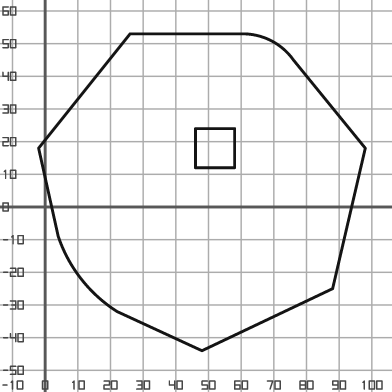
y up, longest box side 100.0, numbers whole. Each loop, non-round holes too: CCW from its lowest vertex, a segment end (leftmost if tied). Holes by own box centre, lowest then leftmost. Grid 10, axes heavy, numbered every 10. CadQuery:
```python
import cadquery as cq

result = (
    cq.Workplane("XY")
    .moveTo(48.0, -44.0)
    .lineTo(88.0, -25.0)
    .lineTo(98.0, 18.0)
    .lineTo(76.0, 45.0)
    .threePointArc((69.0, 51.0), (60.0, 53.0))
    .lineTo(26.0, 53.0)
    .lineTo(-2.0, 18.0)
    .lineTo(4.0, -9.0)
    .threePointArc((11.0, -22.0), (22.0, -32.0))
    .close()
    .moveTo(46.0, 12.0)
    .lineTo(58.0, 12.0)
    .lineTo(58.0, 24.0)
    .lineTo(46.0, 24.0)
    .close()
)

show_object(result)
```